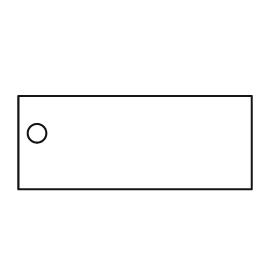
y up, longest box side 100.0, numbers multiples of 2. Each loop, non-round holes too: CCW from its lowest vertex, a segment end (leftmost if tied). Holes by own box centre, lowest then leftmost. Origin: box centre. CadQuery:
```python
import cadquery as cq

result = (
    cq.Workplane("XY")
    .moveTo(-50.0, -20.0)
    .lineTo(50.0, -20.0)
    .lineTo(50.0, 20.0)
    .lineTo(-50.0, 20.0)
    .close()
    .moveTo(-42.0, 4.0)
    .circle(4.0)
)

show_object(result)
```